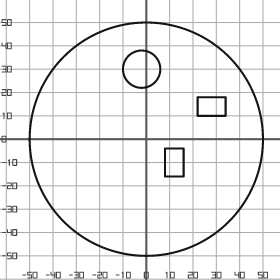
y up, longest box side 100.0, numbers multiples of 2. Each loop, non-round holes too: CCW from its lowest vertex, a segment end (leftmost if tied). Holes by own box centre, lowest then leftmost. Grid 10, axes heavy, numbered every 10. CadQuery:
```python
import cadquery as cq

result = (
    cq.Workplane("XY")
    .moveTo(0.0, 0.0)
    .circle(50.0)
    .moveTo(8.0, -16.0)
    .lineTo(16.0, -16.0)
    .lineTo(16.0, -4.0)
    .lineTo(8.0, -4.0)
    .close()
    .moveTo(22.0, 10.0)
    .lineTo(34.0, 10.0)
    .lineTo(34.0, 18.0)
    .lineTo(22.0, 18.0)
    .close()
    .moveTo(-2.0, 30.0)
    .circle(8.0)
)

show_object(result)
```